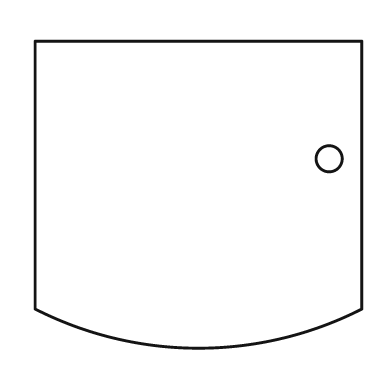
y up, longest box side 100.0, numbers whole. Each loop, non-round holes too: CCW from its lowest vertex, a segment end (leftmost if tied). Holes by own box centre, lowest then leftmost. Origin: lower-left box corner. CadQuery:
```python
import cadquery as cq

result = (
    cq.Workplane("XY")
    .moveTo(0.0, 12.0)
    .threePointArc((50.0, 0.0), (100.0, 12.0))
    .lineTo(100.0, 94.0)
    .lineTo(0.0, 94.0)
    .close()
    .moveTo(90.0, 58.0)
    .circle(4.0)
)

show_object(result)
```